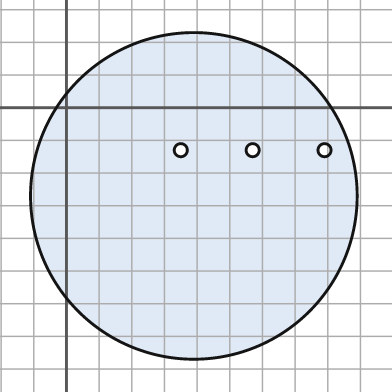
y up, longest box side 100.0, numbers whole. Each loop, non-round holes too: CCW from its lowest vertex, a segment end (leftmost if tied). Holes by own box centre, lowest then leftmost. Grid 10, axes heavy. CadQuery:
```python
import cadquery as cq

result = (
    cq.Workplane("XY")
    .moveTo(39.0, -27.0)
    .circle(50.0)
    .moveTo(35.0, -13.0)
    .circle(2.0)
    .moveTo(57.0, -13.0)
    .circle(2.0)
    .moveTo(79.0, -13.0)
    .circle(2.0)
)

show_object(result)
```